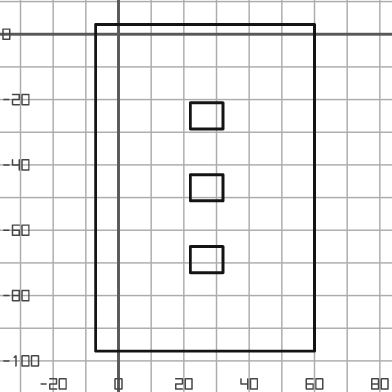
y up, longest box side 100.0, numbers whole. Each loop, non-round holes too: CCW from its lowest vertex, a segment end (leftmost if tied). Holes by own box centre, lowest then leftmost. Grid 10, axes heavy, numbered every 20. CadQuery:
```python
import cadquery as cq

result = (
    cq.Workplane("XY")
    .moveTo(-7.0, -97.0)
    .lineTo(60.0, -97.0)
    .lineTo(60.0, 3.0)
    .lineTo(-7.0, 3.0)
    .close()
    .moveTo(22.0, -73.0)
    .lineTo(32.0, -73.0)
    .lineTo(32.0, -65.0)
    .lineTo(22.0, -65.0)
    .close()
    .moveTo(22.0, -51.0)
    .lineTo(32.0, -51.0)
    .lineTo(32.0, -43.0)
    .lineTo(22.0, -43.0)
    .close()
    .moveTo(22.0, -29.0)
    .lineTo(32.0, -29.0)
    .lineTo(32.0, -21.0)
    .lineTo(22.0, -21.0)
    .close()
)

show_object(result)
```